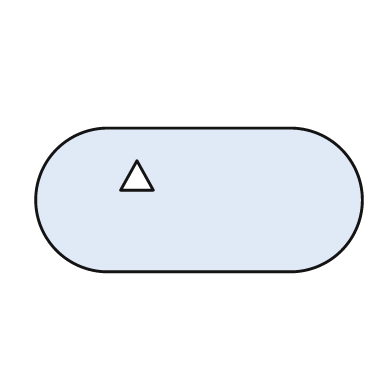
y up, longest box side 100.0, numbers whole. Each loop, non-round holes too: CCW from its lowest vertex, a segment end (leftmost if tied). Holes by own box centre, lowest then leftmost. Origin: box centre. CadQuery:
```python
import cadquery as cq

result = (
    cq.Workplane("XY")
    .moveTo(-28.0, -22.0)
    .lineTo(28.0, -22.0)
    .threePointArc((50.0, 0.0), (28.0, 22.0))
    .lineTo(-28.0, 22.0)
    .threePointArc((-50.0, 0.0), (-28.0, -22.0))
    .close()
    .moveTo(-24.0, 3.0)
    .lineTo(-14.0, 3.0)
    .lineTo(-19.0, 12.0)
    .close()
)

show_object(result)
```